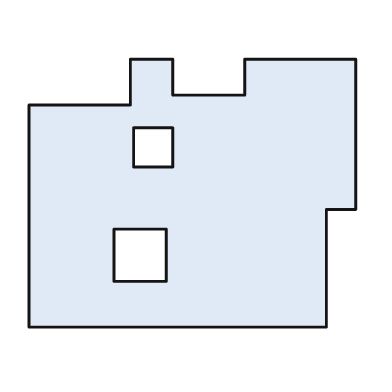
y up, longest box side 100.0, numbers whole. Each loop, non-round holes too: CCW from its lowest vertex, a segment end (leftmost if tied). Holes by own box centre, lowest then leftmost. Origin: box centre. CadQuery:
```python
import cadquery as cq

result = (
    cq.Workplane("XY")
    .moveTo(-50.0, -41.0)
    .lineTo(41.0, -41.0)
    .lineTo(41.0, -5.0)
    .lineTo(50.0, -5.0)
    .lineTo(50.0, 41.0)
    .lineTo(16.0, 41.0)
    .lineTo(16.0, 30.0)
    .lineTo(-6.0, 30.0)
    .lineTo(-6.0, 41.0)
    .lineTo(-19.0, 41.0)
    .lineTo(-19.0, 27.0)
    .lineTo(-50.0, 27.0)
    .close()
    .moveTo(-24.0, -27.0)
    .lineTo(-8.0, -27.0)
    .lineTo(-8.0, -11.0)
    .lineTo(-24.0, -11.0)
    .close()
    .moveTo(-18.0, 8.0)
    .lineTo(-6.0, 8.0)
    .lineTo(-6.0, 20.0)
    .lineTo(-18.0, 20.0)
    .close()
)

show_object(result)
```